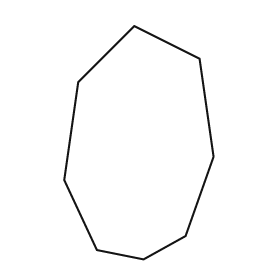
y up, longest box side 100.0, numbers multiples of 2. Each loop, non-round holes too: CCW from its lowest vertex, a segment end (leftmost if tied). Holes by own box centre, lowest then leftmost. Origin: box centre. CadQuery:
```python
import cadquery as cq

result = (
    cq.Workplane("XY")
    .moveTo(2.0, -50.0)
    .lineTo(20.0, -40.0)
    .lineTo(32.0, -6.0)
    .lineTo(26.0, 36.0)
    .lineTo(-2.0, 50.0)
    .lineTo(-26.0, 26.0)
    .lineTo(-32.0, -16.0)
    .lineTo(-18.0, -46.0)
    .close()
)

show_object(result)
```